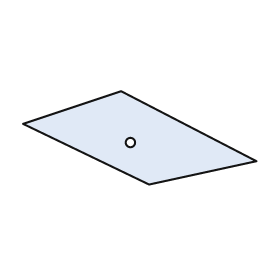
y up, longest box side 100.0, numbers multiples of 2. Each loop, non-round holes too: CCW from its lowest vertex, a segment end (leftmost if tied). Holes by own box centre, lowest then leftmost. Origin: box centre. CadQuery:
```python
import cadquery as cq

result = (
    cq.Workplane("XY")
    .moveTo(4.0, -20.0)
    .lineTo(50.0, -10.0)
    .lineTo(-8.0, 20.0)
    .lineTo(-50.0, 6.0)
    .close()
    .moveTo(-4.0, -2.0)
    .circle(2.0)
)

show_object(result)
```